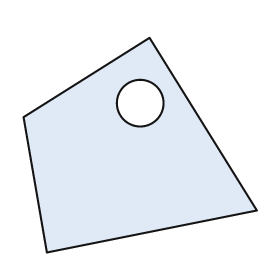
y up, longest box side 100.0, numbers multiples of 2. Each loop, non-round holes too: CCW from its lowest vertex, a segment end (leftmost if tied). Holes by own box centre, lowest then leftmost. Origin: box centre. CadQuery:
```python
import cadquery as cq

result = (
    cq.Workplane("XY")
    .moveTo(-40.0, -46.0)
    .lineTo(50.0, -28.0)
    .lineTo(4.0, 46.0)
    .lineTo(-50.0, 12.0)
    .close()
    .moveTo(0.0, 18.0)
    .circle(10.0)
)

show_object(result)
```